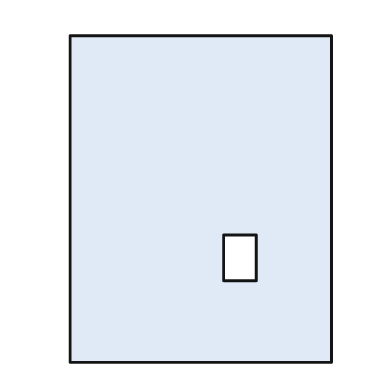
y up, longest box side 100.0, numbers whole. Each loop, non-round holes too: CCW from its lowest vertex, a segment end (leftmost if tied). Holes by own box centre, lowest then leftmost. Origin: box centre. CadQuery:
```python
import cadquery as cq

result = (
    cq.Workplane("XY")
    .moveTo(-40.0, -50.0)
    .lineTo(40.0, -50.0)
    .lineTo(40.0, 50.0)
    .lineTo(-40.0, 50.0)
    .close()
    .moveTo(7.0, -25.0)
    .lineTo(17.0, -25.0)
    .lineTo(17.0, -11.0)
    .lineTo(7.0, -11.0)
    .close()
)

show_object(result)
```